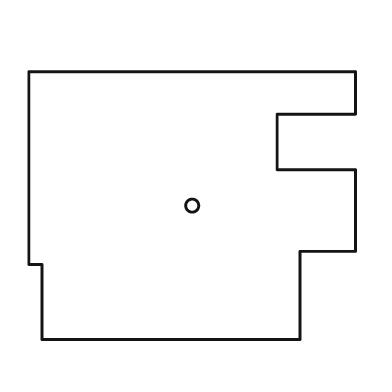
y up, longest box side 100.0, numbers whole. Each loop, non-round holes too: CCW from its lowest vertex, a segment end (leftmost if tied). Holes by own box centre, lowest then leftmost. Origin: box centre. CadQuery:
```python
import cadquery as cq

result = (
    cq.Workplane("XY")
    .moveTo(-46.0, -41.0)
    .lineTo(33.0, -41.0)
    .lineTo(33.0, -14.0)
    .lineTo(50.0, -14.0)
    .lineTo(50.0, 11.0)
    .lineTo(26.0, 11.0)
    .lineTo(26.0, 28.0)
    .lineTo(50.0, 28.0)
    .lineTo(50.0, 41.0)
    .lineTo(-50.0, 41.0)
    .lineTo(-50.0, -18.0)
    .lineTo(-46.0, -18.0)
    .close()
    .moveTo(0.0, 0.0)
    .circle(2.0)
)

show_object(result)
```